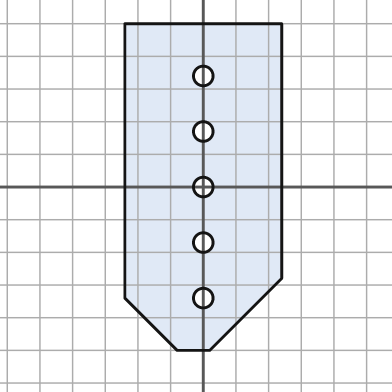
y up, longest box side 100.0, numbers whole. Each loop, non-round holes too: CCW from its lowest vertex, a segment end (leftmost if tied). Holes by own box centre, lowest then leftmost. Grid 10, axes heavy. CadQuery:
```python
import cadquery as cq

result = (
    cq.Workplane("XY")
    .moveTo(-8.0, -50.0)
    .lineTo(2.0, -50.0)
    .lineTo(24.0, -28.0)
    .lineTo(24.0, 50.0)
    .lineTo(-24.0, 50.0)
    .lineTo(-24.0, -34.0)
    .close()
    .moveTo(0.0, -34.0)
    .circle(3.0)
    .moveTo(0.0, -17.0)
    .circle(3.0)
    .moveTo(0.0, 0.0)
    .circle(3.0)
    .moveTo(0.0, 17.0)
    .circle(3.0)
    .moveTo(0.0, 34.0)
    .circle(3.0)
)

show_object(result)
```